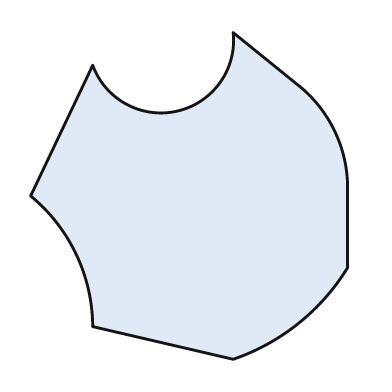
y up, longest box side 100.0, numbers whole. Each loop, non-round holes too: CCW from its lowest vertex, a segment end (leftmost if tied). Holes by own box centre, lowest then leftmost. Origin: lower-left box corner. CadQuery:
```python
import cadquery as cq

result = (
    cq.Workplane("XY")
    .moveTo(62.0, 0.0)
    .threePointArc((82.0, 11.0), (97.0, 28.0))
    .lineTo(97.0, 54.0)
    .threePointArc((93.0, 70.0), (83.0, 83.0))
    .lineTo(62.0, 100.0)
    .threePointArc((45.0, 76.0), (19.0, 90.0))
    .lineTo(0.0, 50.0)
    .threePointArc((14.0, 32.0), (19.0, 10.0))
    .close()
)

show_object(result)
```